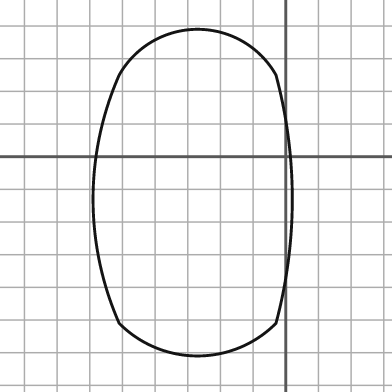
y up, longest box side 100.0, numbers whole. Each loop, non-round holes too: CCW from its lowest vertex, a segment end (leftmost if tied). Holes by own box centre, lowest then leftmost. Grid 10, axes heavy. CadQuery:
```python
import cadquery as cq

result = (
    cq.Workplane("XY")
    .moveTo(-51.0, -51.0)
    .threePointArc((-27.0, -61.0), (-3.0, -51.0))
    .threePointArc((2.0, -13.0), (-3.0, 25.0))
    .threePointArc((-27.0, 39.0), (-51.0, 25.0))
    .threePointArc((-59.0, -13.0), (-51.0, -51.0))
    .close()
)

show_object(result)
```